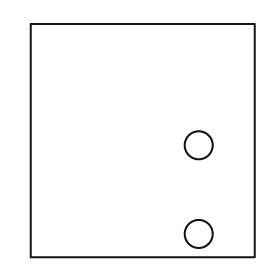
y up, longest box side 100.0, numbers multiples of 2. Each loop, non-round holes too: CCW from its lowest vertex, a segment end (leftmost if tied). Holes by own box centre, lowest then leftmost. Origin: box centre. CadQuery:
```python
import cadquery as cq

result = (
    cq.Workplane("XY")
    .moveTo(-48.0, -50.0)
    .lineTo(48.0, -50.0)
    .lineTo(48.0, 50.0)
    .lineTo(-48.0, 50.0)
    .close()
    .moveTo(24.0, -40.0)
    .circle(6.0)
    .moveTo(24.0, -2.0)
    .circle(6.0)
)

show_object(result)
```